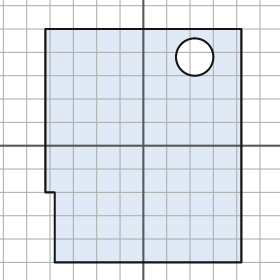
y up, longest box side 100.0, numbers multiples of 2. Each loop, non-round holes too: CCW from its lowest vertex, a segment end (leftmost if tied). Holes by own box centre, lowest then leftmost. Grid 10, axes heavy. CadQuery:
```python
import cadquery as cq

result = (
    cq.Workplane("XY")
    .moveTo(-38.0, -50.0)
    .lineTo(42.0, -50.0)
    .lineTo(42.0, 50.0)
    .lineTo(-42.0, 50.0)
    .lineTo(-42.0, -20.0)
    .lineTo(-38.0, -20.0)
    .close()
    .moveTo(22.0, 38.0)
    .circle(8.0)
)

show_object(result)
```